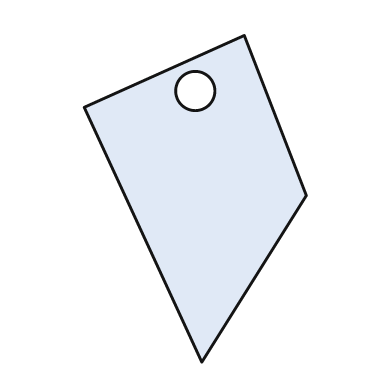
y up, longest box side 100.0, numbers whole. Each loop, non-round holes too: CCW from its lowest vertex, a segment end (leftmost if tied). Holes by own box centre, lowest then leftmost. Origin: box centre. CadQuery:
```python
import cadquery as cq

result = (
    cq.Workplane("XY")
    .moveTo(2.0, -50.0)
    .lineTo(34.0, 1.0)
    .lineTo(15.0, 50.0)
    .lineTo(-34.0, 28.0)
    .close()
    .moveTo(0.0, 33.0)
    .circle(6.0)
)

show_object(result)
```